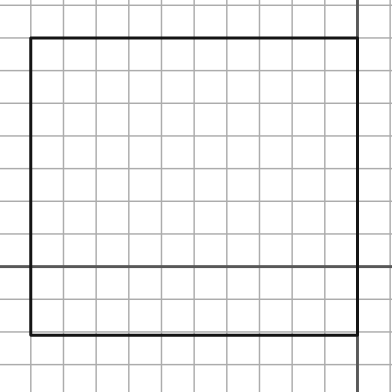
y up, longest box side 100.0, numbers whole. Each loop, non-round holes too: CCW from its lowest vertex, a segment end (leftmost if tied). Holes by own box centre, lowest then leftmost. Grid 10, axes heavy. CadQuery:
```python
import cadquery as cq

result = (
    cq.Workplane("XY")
    .moveTo(-100.0, -21.0)
    .lineTo(0.0, -21.0)
    .lineTo(0.0, 70.0)
    .lineTo(-100.0, 70.0)
    .close()
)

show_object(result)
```